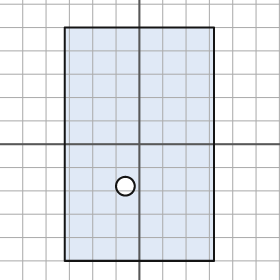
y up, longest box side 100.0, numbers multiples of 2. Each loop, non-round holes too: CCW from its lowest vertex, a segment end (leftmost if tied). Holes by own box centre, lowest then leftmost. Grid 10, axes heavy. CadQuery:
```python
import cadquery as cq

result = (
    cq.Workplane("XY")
    .moveTo(-32.0, -50.0)
    .lineTo(32.0, -50.0)
    .lineTo(32.0, 50.0)
    .lineTo(-32.0, 50.0)
    .close()
    .moveTo(-6.0, -18.0)
    .circle(4.0)
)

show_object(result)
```